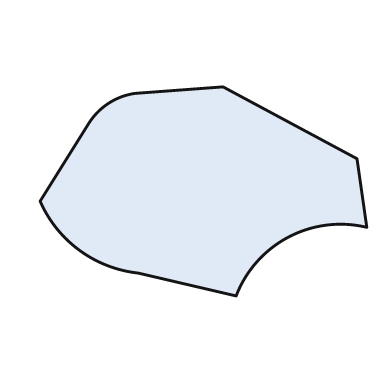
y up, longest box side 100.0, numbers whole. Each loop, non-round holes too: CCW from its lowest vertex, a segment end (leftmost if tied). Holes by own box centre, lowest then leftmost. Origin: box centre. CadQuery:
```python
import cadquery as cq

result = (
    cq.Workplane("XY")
    .moveTo(10.0, -32.0)
    .threePointArc((26.0, -14.0), (50.0, -11.0))
    .lineTo(47.0, 10.0)
    .lineTo(6.0, 32.0)
    .lineTo(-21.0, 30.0)
    .threePointArc((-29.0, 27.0), (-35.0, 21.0))
    .lineTo(-50.0, -3.0)
    .threePointArc((-38.0, -18.0), (-20.0, -25.0))
    .close()
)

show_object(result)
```